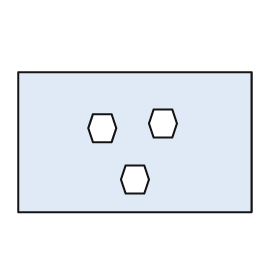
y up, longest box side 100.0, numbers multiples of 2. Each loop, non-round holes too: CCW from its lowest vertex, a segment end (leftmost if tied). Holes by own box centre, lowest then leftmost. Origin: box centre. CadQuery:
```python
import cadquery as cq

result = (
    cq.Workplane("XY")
    .moveTo(-50.0, -30.0)
    .lineTo(50.0, -30.0)
    .lineTo(50.0, 30.0)
    .lineTo(-50.0, 30.0)
    .close()
    .moveTo(-4.0, -22.0)
    .lineTo(4.0, -22.0)
    .lineTo(6.0, -16.0)
    .lineTo(4.0, -10.0)
    .lineTo(-4.0, -10.0)
    .lineTo(-6.0, -16.0)
    .close()
    .moveTo(-18.0, 0.0)
    .lineTo(-10.0, 0.0)
    .lineTo(-8.0, 6.0)
    .lineTo(-10.0, 12.0)
    .lineTo(-18.0, 12.0)
    .lineTo(-20.0, 6.0)
    .close()
    .moveTo(8.0, 2.0)
    .lineTo(16.0, 2.0)
    .lineTo(18.0, 8.0)
    .lineTo(16.0, 14.0)
    .lineTo(8.0, 14.0)
    .lineTo(6.0, 8.0)
    .close()
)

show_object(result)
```